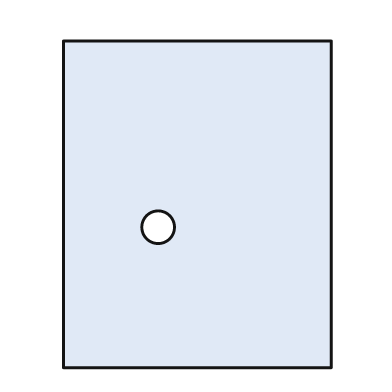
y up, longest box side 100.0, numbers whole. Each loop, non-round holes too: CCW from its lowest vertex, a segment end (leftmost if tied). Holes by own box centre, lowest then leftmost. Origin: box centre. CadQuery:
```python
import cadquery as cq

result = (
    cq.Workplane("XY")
    .moveTo(-41.0, -50.0)
    .lineTo(41.0, -50.0)
    .lineTo(41.0, 50.0)
    .lineTo(-41.0, 50.0)
    .close()
    .moveTo(-12.0, -7.0)
    .circle(5.0)
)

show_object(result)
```